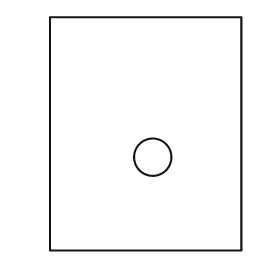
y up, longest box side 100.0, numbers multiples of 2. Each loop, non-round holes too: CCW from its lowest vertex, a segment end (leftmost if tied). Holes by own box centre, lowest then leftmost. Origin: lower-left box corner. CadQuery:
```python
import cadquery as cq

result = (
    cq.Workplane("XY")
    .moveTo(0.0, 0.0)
    .lineTo(82.0, 0.0)
    .lineTo(82.0, 100.0)
    .lineTo(0.0, 100.0)
    .close()
    .moveTo(44.0, 40.0)
    .circle(8.0)
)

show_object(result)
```